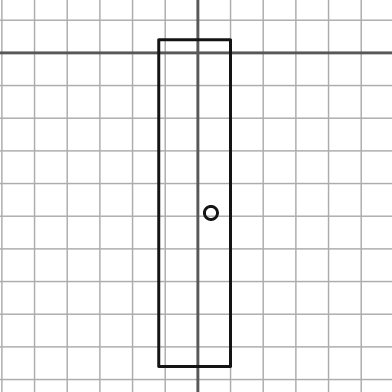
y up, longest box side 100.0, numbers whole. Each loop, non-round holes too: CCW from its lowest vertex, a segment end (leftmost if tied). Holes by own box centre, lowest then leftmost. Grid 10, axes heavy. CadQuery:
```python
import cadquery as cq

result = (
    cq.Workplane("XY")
    .moveTo(-12.0, -96.0)
    .lineTo(10.0, -96.0)
    .lineTo(10.0, 4.0)
    .lineTo(-12.0, 4.0)
    .close()
    .moveTo(4.0, -49.0)
    .circle(2.0)
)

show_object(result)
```